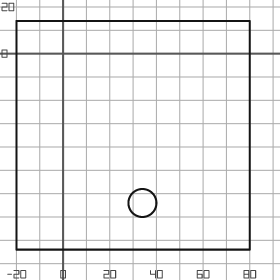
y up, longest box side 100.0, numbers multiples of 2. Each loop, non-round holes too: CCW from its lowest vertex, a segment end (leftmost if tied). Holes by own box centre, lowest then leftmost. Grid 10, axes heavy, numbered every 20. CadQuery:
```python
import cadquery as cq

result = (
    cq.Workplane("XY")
    .moveTo(-20.0, -84.0)
    .lineTo(80.0, -84.0)
    .lineTo(80.0, 14.0)
    .lineTo(-20.0, 14.0)
    .close()
    .moveTo(34.0, -64.0)
    .circle(6.0)
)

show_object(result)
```